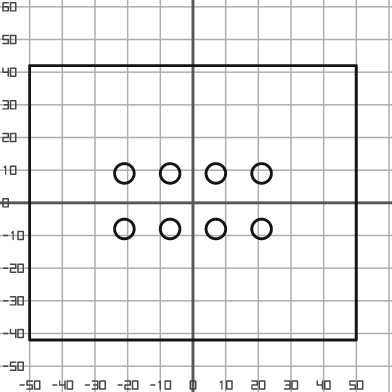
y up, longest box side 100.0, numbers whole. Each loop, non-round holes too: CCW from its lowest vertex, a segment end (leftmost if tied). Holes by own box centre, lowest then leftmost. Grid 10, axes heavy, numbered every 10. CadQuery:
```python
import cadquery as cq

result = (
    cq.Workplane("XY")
    .moveTo(-50.0, -42.0)
    .lineTo(50.0, -42.0)
    .lineTo(50.0, 42.0)
    .lineTo(-50.0, 42.0)
    .close()
    .moveTo(-21.0, -8.0)
    .circle(3.0)
    .moveTo(-7.0, -8.0)
    .circle(3.0)
    .moveTo(7.0, -8.0)
    .circle(3.0)
    .moveTo(21.0, -8.0)
    .circle(3.0)
    .moveTo(-21.0, 9.0)
    .circle(3.0)
    .moveTo(-7.0, 9.0)
    .circle(3.0)
    .moveTo(7.0, 9.0)
    .circle(3.0)
    .moveTo(21.0, 9.0)
    .circle(3.0)
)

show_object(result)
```